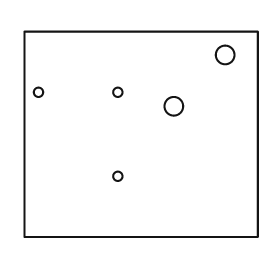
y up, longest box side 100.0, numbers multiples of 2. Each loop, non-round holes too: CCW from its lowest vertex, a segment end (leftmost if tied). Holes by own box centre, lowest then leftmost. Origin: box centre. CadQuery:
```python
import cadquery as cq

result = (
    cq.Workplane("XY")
    .moveTo(-50.0, -44.0)
    .lineTo(50.0, -44.0)
    .lineTo(50.0, 44.0)
    .lineTo(-50.0, 44.0)
    .close()
    .moveTo(-10.0, -18.0)
    .circle(2.0)
    .moveTo(14.0, 12.0)
    .circle(4.0)
    .moveTo(-44.0, 18.0)
    .circle(2.0)
    .moveTo(-10.0, 18.0)
    .circle(2.0)
    .moveTo(36.0, 34.0)
    .circle(4.0)
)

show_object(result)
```